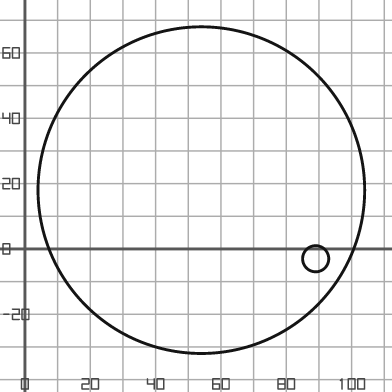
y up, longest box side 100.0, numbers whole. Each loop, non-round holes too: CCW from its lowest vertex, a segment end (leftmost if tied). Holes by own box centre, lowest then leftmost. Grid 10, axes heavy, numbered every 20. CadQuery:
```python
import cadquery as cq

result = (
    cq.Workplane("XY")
    .moveTo(54.0, 18.0)
    .circle(50.0)
    .moveTo(89.0, -3.0)
    .circle(4.0)
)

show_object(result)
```